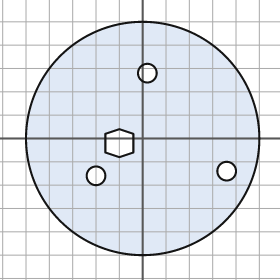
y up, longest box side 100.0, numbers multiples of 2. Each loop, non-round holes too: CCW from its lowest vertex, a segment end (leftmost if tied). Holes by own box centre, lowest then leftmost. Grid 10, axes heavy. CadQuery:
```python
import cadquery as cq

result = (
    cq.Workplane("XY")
    .moveTo(0.0, 0.0)
    .circle(50.0)
    .moveTo(-20.0, -16.0)
    .circle(4.0)
    .moveTo(36.0, -14.0)
    .circle(4.0)
    .moveTo(-10.0, -8.0)
    .lineTo(-4.0, -6.0)
    .lineTo(-4.0, 2.0)
    .lineTo(-10.0, 4.0)
    .lineTo(-16.0, 2.0)
    .lineTo(-16.0, -6.0)
    .close()
    .moveTo(2.0, 28.0)
    .circle(4.0)
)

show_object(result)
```